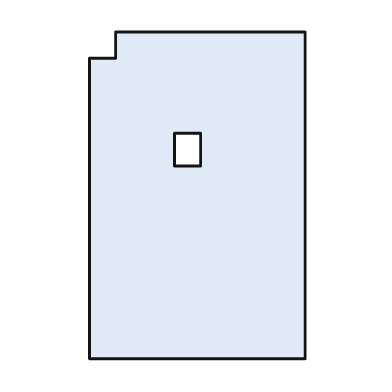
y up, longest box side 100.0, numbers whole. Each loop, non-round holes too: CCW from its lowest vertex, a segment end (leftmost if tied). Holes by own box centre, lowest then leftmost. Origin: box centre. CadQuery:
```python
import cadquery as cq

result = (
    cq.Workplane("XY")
    .moveTo(-33.0, -50.0)
    .lineTo(33.0, -50.0)
    .lineTo(33.0, 50.0)
    .lineTo(-25.0, 50.0)
    .lineTo(-25.0, 42.0)
    .lineTo(-33.0, 42.0)
    .close()
    .moveTo(-7.0, 9.0)
    .lineTo(1.0, 9.0)
    .lineTo(1.0, 19.0)
    .lineTo(-7.0, 19.0)
    .close()
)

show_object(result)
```